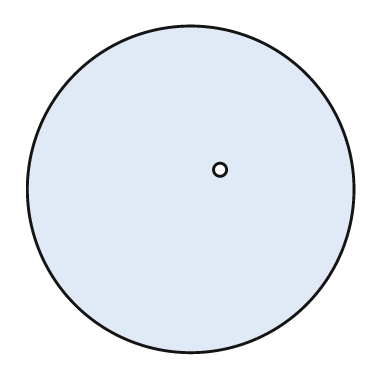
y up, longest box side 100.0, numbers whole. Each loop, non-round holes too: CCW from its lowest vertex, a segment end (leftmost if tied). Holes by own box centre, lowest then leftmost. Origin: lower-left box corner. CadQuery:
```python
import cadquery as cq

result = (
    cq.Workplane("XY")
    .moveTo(50.0, 50.0)
    .circle(50.0)
    .moveTo(59.0, 56.0)
    .circle(2.0)
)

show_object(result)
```